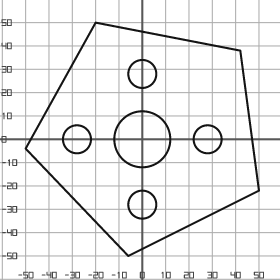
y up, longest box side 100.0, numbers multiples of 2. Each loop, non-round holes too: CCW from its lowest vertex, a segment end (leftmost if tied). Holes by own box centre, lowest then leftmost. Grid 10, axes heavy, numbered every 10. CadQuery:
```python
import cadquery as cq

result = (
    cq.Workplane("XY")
    .moveTo(-6.0, -50.0)
    .lineTo(50.0, -22.0)
    .lineTo(42.0, 38.0)
    .lineTo(-20.0, 50.0)
    .lineTo(-50.0, -4.0)
    .close()
    .moveTo(0.0, -28.0)
    .circle(6.0)
    .moveTo(-28.0, 0.0)
    .circle(6.0)
    .moveTo(0.0, 0.0)
    .circle(12.0)
    .moveTo(28.0, 0.0)
    .circle(6.0)
    .moveTo(0.0, 28.0)
    .circle(6.0)
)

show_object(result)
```